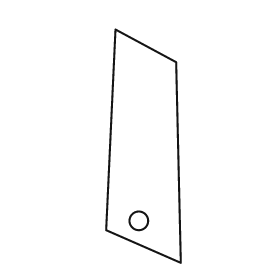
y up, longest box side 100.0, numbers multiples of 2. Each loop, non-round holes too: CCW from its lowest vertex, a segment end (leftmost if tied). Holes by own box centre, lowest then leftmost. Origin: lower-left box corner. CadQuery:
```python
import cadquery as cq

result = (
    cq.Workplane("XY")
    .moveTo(32.0, 0.0)
    .lineTo(30.0, 86.0)
    .lineTo(4.0, 100.0)
    .lineTo(0.0, 14.0)
    .close()
    .moveTo(14.0, 18.0)
    .circle(4.0)
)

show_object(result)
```